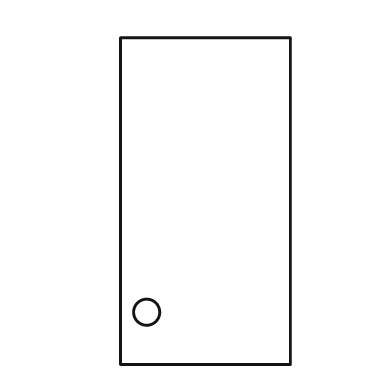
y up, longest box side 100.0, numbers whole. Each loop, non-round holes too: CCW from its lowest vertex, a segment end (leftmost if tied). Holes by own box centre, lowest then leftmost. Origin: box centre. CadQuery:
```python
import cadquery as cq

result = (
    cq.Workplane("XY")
    .moveTo(-26.0, -50.0)
    .lineTo(26.0, -50.0)
    .lineTo(26.0, 50.0)
    .lineTo(-26.0, 50.0)
    .close()
    .moveTo(-18.0, -34.0)
    .circle(4.0)
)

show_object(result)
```